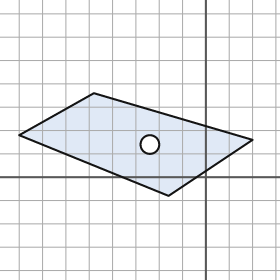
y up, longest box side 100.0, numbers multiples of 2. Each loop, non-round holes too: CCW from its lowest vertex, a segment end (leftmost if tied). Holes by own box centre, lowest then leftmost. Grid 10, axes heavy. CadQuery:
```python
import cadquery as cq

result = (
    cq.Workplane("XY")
    .moveTo(-16.0, -8.0)
    .lineTo(20.0, 16.0)
    .lineTo(-48.0, 36.0)
    .lineTo(-80.0, 18.0)
    .close()
    .moveTo(-24.0, 14.0)
    .circle(4.0)
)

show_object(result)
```